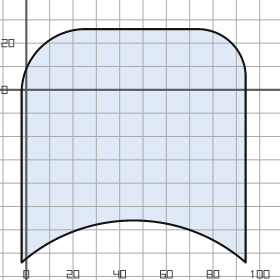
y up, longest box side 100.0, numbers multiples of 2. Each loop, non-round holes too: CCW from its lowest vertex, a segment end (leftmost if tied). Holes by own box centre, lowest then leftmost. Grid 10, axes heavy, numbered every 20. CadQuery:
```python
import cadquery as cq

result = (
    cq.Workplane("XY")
    .moveTo(-2.0, -74.0)
    .threePointArc((46.0, -56.0), (94.0, -74.0))
    .lineTo(94.0, 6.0)
    .threePointArc((88.0, 20.0), (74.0, 26.0))
    .lineTo(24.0, 26.0)
    .threePointArc((6.0, 18.0), (-2.0, 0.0))
    .close()
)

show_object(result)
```